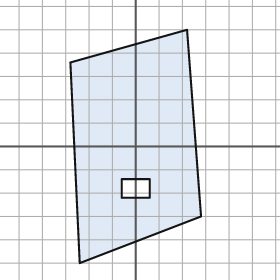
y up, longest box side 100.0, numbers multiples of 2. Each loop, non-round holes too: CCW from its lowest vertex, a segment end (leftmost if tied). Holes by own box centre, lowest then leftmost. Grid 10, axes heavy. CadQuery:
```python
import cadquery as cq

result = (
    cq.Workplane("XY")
    .moveTo(-24.0, -50.0)
    .lineTo(28.0, -30.0)
    .lineTo(22.0, 50.0)
    .lineTo(-28.0, 36.0)
    .close()
    .moveTo(-6.0, -22.0)
    .lineTo(6.0, -22.0)
    .lineTo(6.0, -14.0)
    .lineTo(-6.0, -14.0)
    .close()
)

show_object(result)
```